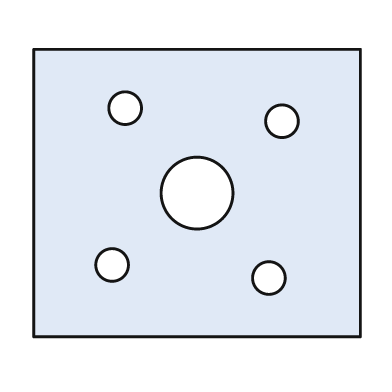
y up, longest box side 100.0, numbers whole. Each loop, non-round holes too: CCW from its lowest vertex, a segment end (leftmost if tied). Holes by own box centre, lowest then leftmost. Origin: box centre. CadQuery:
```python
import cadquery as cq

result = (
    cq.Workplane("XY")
    .moveTo(-50.0, -44.0)
    .lineTo(50.0, -44.0)
    .lineTo(50.0, 44.0)
    .lineTo(-50.0, 44.0)
    .close()
    .moveTo(22.0, -26.0)
    .circle(5.0)
    .moveTo(-26.0, -22.0)
    .circle(5.0)
    .moveTo(0.0, 0.0)
    .circle(11.0)
    .moveTo(26.0, 22.0)
    .circle(5.0)
    .moveTo(-22.0, 26.0)
    .circle(5.0)
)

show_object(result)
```